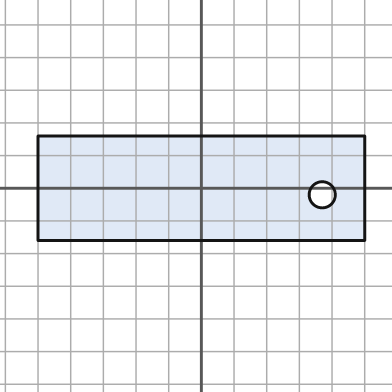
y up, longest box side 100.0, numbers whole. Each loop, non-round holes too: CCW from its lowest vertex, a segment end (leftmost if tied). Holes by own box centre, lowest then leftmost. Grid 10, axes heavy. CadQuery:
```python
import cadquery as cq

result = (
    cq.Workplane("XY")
    .moveTo(-50.0, -16.0)
    .lineTo(50.0, -16.0)
    .lineTo(50.0, 16.0)
    .lineTo(-50.0, 16.0)
    .close()
    .moveTo(37.0, -2.0)
    .circle(4.0)
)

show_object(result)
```